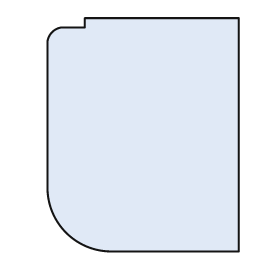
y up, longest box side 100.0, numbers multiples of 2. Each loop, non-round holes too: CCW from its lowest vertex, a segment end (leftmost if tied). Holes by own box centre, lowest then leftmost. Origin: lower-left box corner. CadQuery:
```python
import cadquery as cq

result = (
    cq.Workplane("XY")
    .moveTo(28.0, 0.0)
    .lineTo(82.0, 0.0)
    .lineTo(82.0, 100.0)
    .lineTo(16.0, 100.0)
    .lineTo(16.0, 96.0)
    .lineTo(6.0, 96.0)
    .threePointArc((2.0, 94.0), (0.0, 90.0))
    .lineTo(0.0, 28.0)
    .threePointArc((8.0, 8.0), (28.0, 0.0))
    .close()
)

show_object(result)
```